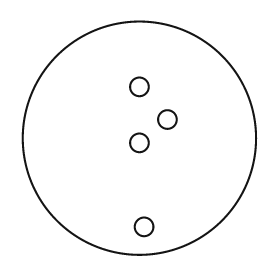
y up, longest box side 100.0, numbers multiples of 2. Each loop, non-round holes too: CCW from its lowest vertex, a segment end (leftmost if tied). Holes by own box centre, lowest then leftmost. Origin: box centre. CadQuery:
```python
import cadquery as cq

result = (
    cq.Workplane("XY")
    .moveTo(0.0, 0.0)
    .circle(50.0)
    .moveTo(2.0, -38.0)
    .circle(4.0)
    .moveTo(0.0, -2.0)
    .circle(4.0)
    .moveTo(12.0, 8.0)
    .circle(4.0)
    .moveTo(0.0, 22.0)
    .circle(4.0)
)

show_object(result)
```